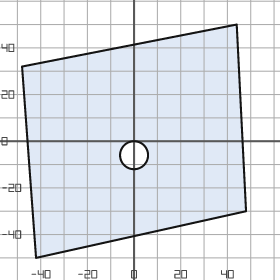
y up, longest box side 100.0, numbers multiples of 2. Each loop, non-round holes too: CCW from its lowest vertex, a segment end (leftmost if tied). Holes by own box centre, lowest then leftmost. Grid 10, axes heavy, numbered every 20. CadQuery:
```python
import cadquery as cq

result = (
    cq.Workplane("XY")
    .moveTo(-42.0, -50.0)
    .lineTo(48.0, -30.0)
    .lineTo(44.0, 50.0)
    .lineTo(-48.0, 32.0)
    .close()
    .moveTo(0.0, -6.0)
    .circle(6.0)
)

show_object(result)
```